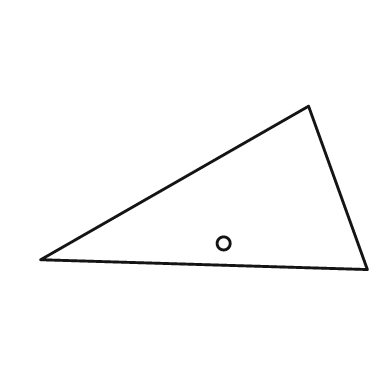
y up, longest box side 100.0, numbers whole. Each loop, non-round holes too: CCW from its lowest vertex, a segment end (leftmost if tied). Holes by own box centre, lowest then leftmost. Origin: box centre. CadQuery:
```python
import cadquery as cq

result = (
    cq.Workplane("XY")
    .moveTo(50.0, -25.0)
    .lineTo(32.0, 25.0)
    .lineTo(-50.0, -22.0)
    .close()
    .moveTo(6.0, -17.0)
    .circle(2.0)
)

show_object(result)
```